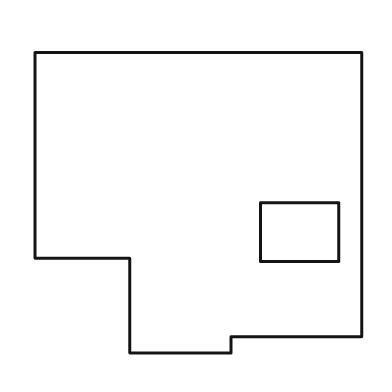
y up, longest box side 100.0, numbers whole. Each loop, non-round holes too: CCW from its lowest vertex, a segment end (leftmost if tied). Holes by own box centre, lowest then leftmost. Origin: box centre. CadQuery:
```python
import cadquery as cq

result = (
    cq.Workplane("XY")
    .moveTo(-21.0, -46.0)
    .lineTo(10.0, -46.0)
    .lineTo(10.0, -41.0)
    .lineTo(50.0, -41.0)
    .lineTo(50.0, 46.0)
    .lineTo(-50.0, 46.0)
    .lineTo(-50.0, -17.0)
    .lineTo(-21.0, -17.0)
    .close()
    .moveTo(19.0, -18.0)
    .lineTo(43.0, -18.0)
    .lineTo(43.0, 0.0)
    .lineTo(19.0, 0.0)
    .close()
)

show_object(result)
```